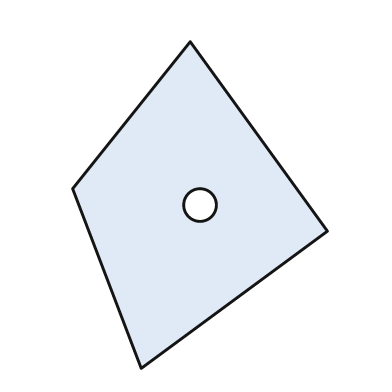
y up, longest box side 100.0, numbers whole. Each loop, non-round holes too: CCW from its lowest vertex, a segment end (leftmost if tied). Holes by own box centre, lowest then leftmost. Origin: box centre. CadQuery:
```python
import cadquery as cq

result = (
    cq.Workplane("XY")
    .moveTo(-18.0, -50.0)
    .lineTo(39.0, -8.0)
    .lineTo(-3.0, 50.0)
    .lineTo(-39.0, 5.0)
    .close()
    .moveTo(0.0, 0.0)
    .circle(5.0)
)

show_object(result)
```